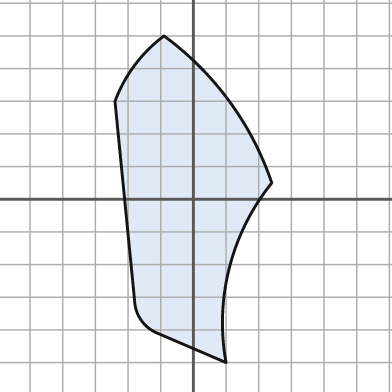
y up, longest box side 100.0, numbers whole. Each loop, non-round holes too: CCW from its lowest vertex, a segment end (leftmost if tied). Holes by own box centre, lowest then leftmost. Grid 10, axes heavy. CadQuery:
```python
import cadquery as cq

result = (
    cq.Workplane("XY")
    .moveTo(10.0, -50.0)
    .threePointArc((11.0, -21.0), (24.0, 5.0))
    .threePointArc((11.0, 30.0), (-9.0, 50.0))
    .threePointArc((-18.0, 41.0), (-24.0, 30.0))
    .lineTo(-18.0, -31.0)
    .threePointArc((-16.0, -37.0), (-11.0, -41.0))
    .close()
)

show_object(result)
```